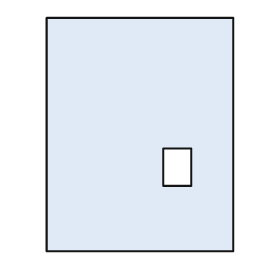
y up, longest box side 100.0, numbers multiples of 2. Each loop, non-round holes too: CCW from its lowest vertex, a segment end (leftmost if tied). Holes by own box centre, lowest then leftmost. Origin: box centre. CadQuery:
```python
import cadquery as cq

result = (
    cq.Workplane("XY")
    .moveTo(-40.0, -50.0)
    .lineTo(40.0, -50.0)
    .lineTo(40.0, 50.0)
    .lineTo(-40.0, 50.0)
    .close()
    .moveTo(10.0, -22.0)
    .lineTo(22.0, -22.0)
    .lineTo(22.0, -6.0)
    .lineTo(10.0, -6.0)
    .close()
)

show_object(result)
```